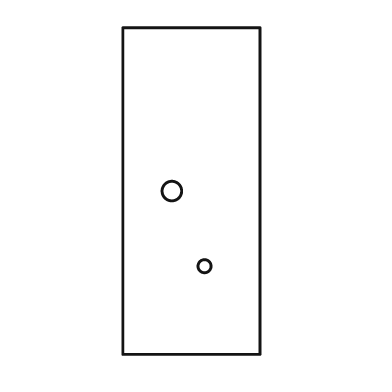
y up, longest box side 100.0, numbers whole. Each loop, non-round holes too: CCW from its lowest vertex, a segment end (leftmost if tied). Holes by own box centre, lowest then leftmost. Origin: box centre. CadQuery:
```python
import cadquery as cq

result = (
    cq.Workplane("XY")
    .moveTo(-21.0, -50.0)
    .lineTo(21.0, -50.0)
    .lineTo(21.0, 50.0)
    .lineTo(-21.0, 50.0)
    .close()
    .moveTo(4.0, -23.0)
    .circle(2.0)
    .moveTo(-6.0, 0.0)
    .circle(3.0)
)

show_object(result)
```